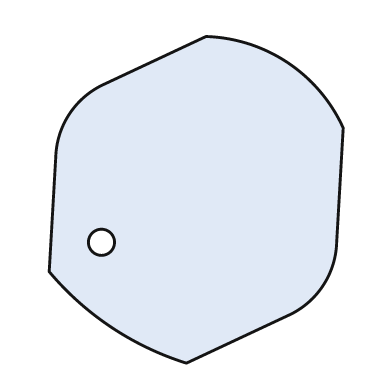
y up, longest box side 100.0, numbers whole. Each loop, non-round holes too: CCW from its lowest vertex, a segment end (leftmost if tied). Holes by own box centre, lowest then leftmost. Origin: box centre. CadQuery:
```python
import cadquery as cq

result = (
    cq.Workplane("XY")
    .moveTo(-3.0, -50.0)
    .lineTo(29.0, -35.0)
    .threePointArc((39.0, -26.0), (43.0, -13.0))
    .lineTo(45.0, 22.0)
    .threePointArc((28.0, 42.0), (3.0, 50.0))
    .lineTo(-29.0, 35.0)
    .threePointArc((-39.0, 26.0), (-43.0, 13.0))
    .lineTo(-45.0, -22.0)
    .threePointArc((-26.0, -39.0), (-3.0, -50.0))
    .close()
    .moveTo(-29.0, -13.0)
    .circle(4.0)
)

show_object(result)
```